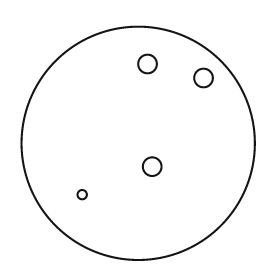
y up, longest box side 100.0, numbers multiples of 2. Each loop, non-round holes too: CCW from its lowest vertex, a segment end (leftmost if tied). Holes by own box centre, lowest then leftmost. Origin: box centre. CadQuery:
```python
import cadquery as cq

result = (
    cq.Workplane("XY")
    .moveTo(0.0, 0.0)
    .circle(50.0)
    .moveTo(-24.0, -22.0)
    .circle(2.0)
    .moveTo(6.0, -10.0)
    .circle(4.0)
    .moveTo(28.0, 28.0)
    .circle(4.0)
    .moveTo(4.0, 34.0)
    .circle(4.0)
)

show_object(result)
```